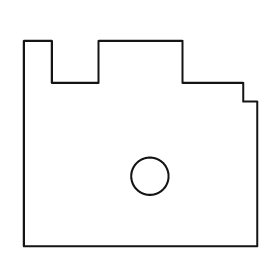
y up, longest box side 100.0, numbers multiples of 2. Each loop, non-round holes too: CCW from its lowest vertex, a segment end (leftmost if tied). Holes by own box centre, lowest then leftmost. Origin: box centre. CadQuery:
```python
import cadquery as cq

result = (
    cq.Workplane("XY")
    .moveTo(-50.0, -44.0)
    .lineTo(50.0, -44.0)
    .lineTo(50.0, 18.0)
    .lineTo(44.0, 18.0)
    .lineTo(44.0, 26.0)
    .lineTo(18.0, 26.0)
    .lineTo(18.0, 44.0)
    .lineTo(-18.0, 44.0)
    .lineTo(-18.0, 26.0)
    .lineTo(-38.0, 26.0)
    .lineTo(-38.0, 44.0)
    .lineTo(-50.0, 44.0)
    .close()
    .moveTo(4.0, -14.0)
    .circle(8.0)
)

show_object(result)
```